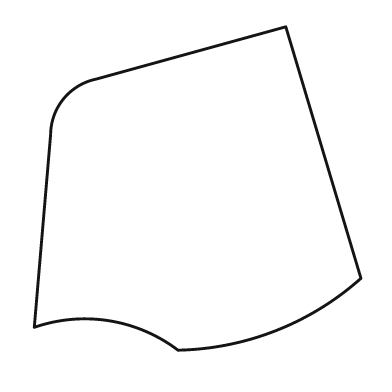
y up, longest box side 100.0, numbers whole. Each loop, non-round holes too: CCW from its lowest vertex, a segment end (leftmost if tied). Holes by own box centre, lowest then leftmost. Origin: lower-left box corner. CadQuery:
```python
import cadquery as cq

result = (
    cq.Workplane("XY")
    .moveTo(44.0, 0.0)
    .threePointArc((74.0, 6.0), (100.0, 22.0))
    .lineTo(77.0, 99.0)
    .lineTo(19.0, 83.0)
    .threePointArc((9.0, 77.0), (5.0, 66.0))
    .lineTo(0.0, 7.0)
    .threePointArc((23.0, 9.0), (44.0, 0.0))
    .close()
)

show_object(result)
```